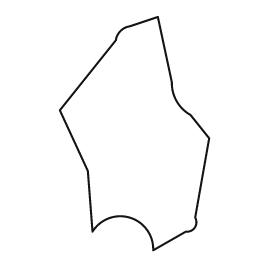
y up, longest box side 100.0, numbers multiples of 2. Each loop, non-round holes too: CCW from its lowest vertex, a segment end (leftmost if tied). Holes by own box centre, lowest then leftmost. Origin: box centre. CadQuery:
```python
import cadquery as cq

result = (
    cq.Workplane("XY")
    .moveTo(8.0, -50.0)
    .lineTo(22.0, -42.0)
    .threePointArc((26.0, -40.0), (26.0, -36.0))
    .lineTo(32.0, -2.0)
    .lineTo(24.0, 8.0)
    .threePointArc((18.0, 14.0), (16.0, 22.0))
    .lineTo(10.0, 50.0)
    .lineTo(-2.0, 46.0)
    .threePointArc((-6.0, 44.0), (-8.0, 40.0))
    .lineTo(-32.0, 10.0)
    .lineTo(-20.0, -16.0)
    .lineTo(-18.0, -42.0)
    .threePointArc((-2.0, -36.0), (8.0, -50.0))
    .close()
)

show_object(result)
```